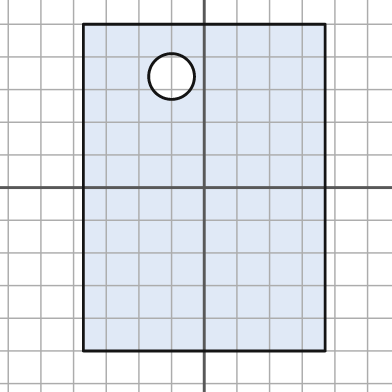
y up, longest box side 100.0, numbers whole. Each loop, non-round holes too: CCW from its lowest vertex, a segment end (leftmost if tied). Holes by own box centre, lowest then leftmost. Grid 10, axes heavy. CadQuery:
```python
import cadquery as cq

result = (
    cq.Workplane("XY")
    .moveTo(-37.0, -50.0)
    .lineTo(37.0, -50.0)
    .lineTo(37.0, 50.0)
    .lineTo(-37.0, 50.0)
    .close()
    .moveTo(-10.0, 34.0)
    .circle(7.0)
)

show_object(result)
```